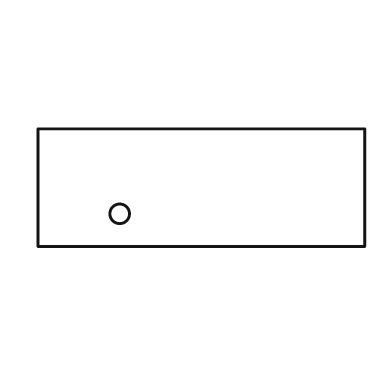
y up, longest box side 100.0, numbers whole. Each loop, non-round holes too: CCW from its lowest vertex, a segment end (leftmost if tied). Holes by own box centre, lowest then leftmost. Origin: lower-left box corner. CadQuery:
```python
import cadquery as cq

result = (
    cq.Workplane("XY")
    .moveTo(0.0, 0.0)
    .lineTo(100.0, 0.0)
    .lineTo(100.0, 36.0)
    .lineTo(0.0, 36.0)
    .close()
    .moveTo(25.0, 10.0)
    .circle(3.0)
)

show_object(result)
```